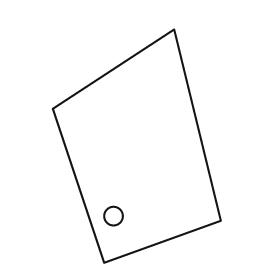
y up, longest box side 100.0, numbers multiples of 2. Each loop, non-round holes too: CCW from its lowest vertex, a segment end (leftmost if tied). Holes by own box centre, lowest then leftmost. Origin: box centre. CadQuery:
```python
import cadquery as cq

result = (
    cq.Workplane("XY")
    .moveTo(-14.0, -50.0)
    .lineTo(36.0, -32.0)
    .lineTo(16.0, 50.0)
    .lineTo(-36.0, 16.0)
    .close()
    .moveTo(-10.0, -30.0)
    .circle(4.0)
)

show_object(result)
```